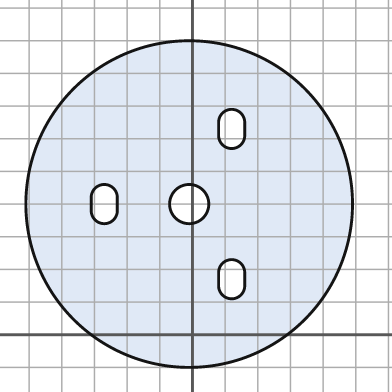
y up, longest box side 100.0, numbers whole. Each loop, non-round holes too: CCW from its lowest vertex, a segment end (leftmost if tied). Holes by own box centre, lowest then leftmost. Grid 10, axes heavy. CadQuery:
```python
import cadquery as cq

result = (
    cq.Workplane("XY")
    .moveTo(-1.0, 40.0)
    .circle(50.0)
    .moveTo(8.0, 15.0)
    .threePointArc((12.0, 11.0), (16.0, 15.0))
    .lineTo(16.0, 19.0)
    .threePointArc((12.0, 23.0), (8.0, 19.0))
    .close()
    .moveTo(-31.0, 38.0)
    .threePointArc((-27.0, 34.0), (-23.0, 38.0))
    .lineTo(-23.0, 42.0)
    .threePointArc((-27.0, 46.0), (-31.0, 42.0))
    .close()
    .moveTo(-1.0, 40.0)
    .circle(6.0)
    .moveTo(8.0, 61.0)
    .threePointArc((12.0, 57.0), (16.0, 61.0))
    .lineTo(16.0, 65.0)
    .threePointArc((12.0, 69.0), (8.0, 65.0))
    .close()
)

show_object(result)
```